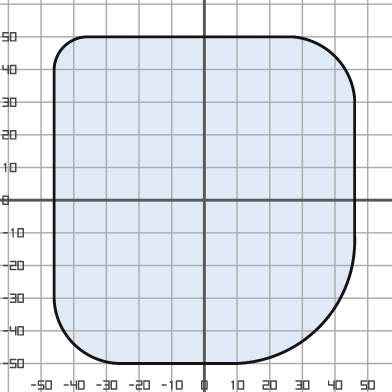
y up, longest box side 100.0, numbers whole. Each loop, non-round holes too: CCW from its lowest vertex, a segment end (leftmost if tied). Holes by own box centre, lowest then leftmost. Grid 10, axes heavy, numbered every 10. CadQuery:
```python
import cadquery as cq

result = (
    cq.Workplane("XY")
    .moveTo(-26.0, -50.0)
    .lineTo(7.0, -50.0)
    .threePointArc((35.0, -39.0), (46.0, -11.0))
    .lineTo(46.0, 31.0)
    .threePointArc((40.0, 44.0), (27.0, 50.0))
    .lineTo(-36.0, 50.0)
    .threePointArc((-43.0, 47.0), (-46.0, 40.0))
    .lineTo(-46.0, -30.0)
    .threePointArc((-40.0, -44.0), (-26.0, -50.0))
    .close()
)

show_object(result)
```